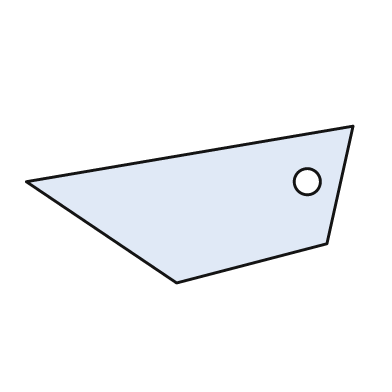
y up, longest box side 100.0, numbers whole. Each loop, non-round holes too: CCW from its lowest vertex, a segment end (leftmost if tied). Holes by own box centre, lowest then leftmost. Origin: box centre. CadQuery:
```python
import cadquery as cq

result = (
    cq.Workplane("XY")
    .moveTo(-4.0, -24.0)
    .lineTo(42.0, -12.0)
    .lineTo(50.0, 24.0)
    .lineTo(-50.0, 7.0)
    .close()
    .moveTo(36.0, 7.0)
    .circle(4.0)
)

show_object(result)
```